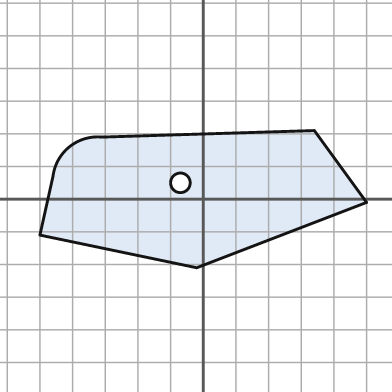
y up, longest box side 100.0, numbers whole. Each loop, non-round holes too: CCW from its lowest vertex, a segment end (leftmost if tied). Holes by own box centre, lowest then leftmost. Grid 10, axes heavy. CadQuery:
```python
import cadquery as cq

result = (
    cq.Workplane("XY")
    .moveTo(-2.0, -21.0)
    .lineTo(50.0, -1.0)
    .lineTo(34.0, 21.0)
    .lineTo(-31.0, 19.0)
    .threePointArc((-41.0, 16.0), (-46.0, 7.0))
    .lineTo(-50.0, -11.0)
    .close()
    .moveTo(-7.0, 5.0)
    .circle(3.0)
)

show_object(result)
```